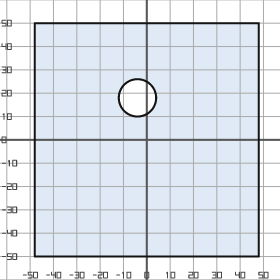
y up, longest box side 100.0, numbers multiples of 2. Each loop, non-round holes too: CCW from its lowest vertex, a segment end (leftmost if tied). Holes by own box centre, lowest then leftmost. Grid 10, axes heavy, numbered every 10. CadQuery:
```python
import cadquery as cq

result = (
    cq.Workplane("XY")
    .moveTo(-48.0, -50.0)
    .lineTo(48.0, -50.0)
    .lineTo(48.0, 50.0)
    .lineTo(-48.0, 50.0)
    .close()
    .moveTo(-4.0, 18.0)
    .circle(8.0)
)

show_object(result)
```